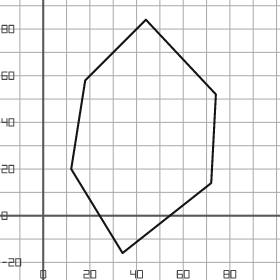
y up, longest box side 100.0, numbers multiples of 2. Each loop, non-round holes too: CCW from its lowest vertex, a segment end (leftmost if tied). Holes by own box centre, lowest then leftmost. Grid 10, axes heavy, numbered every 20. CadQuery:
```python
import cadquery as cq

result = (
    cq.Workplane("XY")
    .moveTo(34.0, -16.0)
    .lineTo(72.0, 14.0)
    .lineTo(74.0, 52.0)
    .lineTo(44.0, 84.0)
    .lineTo(18.0, 58.0)
    .lineTo(12.0, 20.0)
    .close()
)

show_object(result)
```